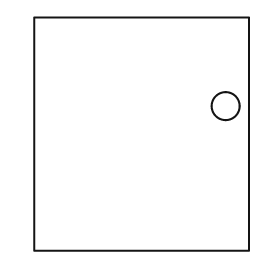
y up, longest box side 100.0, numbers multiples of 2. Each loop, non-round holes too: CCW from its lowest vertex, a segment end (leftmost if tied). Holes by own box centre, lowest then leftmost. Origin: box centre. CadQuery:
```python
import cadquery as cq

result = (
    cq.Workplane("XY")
    .moveTo(-46.0, -50.0)
    .lineTo(46.0, -50.0)
    .lineTo(46.0, 50.0)
    .lineTo(-46.0, 50.0)
    .close()
    .moveTo(36.0, 12.0)
    .circle(6.0)
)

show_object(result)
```